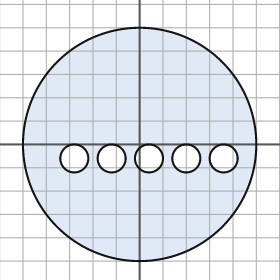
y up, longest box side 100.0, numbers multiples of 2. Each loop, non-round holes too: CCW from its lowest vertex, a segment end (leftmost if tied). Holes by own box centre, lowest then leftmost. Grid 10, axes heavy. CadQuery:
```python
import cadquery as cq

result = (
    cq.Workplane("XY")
    .moveTo(0.0, 0.0)
    .circle(50.0)
    .moveTo(-28.0, -6.0)
    .circle(6.0)
    .moveTo(-12.0, -6.0)
    .circle(6.0)
    .moveTo(4.0, -6.0)
    .circle(6.0)
    .moveTo(20.0, -6.0)
    .circle(6.0)
    .moveTo(36.0, -6.0)
    .circle(6.0)
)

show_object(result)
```